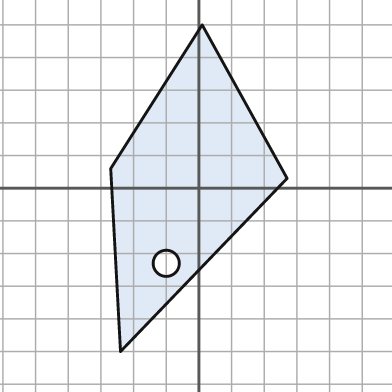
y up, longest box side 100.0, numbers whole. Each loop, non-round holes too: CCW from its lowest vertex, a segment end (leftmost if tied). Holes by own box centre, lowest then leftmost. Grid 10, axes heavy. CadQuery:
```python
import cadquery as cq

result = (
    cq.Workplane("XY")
    .moveTo(-24.0, -50.0)
    .lineTo(27.0, 3.0)
    .lineTo(1.0, 50.0)
    .lineTo(-27.0, 6.0)
    .close()
    .moveTo(-10.0, -23.0)
    .circle(4.0)
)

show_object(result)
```